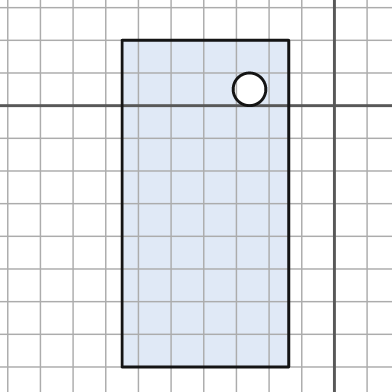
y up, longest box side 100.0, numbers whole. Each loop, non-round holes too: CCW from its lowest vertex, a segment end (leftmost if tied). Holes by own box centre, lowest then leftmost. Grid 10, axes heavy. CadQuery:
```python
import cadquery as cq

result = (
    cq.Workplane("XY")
    .moveTo(-65.0, -80.0)
    .lineTo(-14.0, -80.0)
    .lineTo(-14.0, 20.0)
    .lineTo(-65.0, 20.0)
    .close()
    .moveTo(-26.0, 5.0)
    .circle(5.0)
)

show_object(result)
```